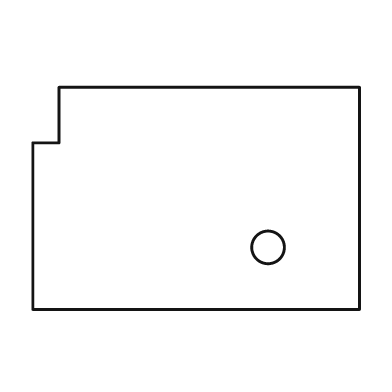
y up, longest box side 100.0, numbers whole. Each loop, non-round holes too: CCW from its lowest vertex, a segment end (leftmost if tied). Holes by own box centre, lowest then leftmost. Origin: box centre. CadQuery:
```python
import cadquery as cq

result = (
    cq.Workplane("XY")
    .moveTo(-50.0, -34.0)
    .lineTo(50.0, -34.0)
    .lineTo(50.0, 34.0)
    .lineTo(-42.0, 34.0)
    .lineTo(-42.0, 17.0)
    .lineTo(-50.0, 17.0)
    .close()
    .moveTo(22.0, -15.0)
    .circle(5.0)
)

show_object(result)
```